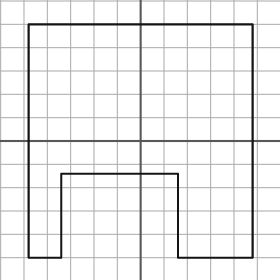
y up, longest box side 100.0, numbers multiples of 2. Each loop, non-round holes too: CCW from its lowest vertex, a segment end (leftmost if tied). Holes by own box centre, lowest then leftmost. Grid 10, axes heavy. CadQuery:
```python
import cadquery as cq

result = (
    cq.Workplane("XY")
    .moveTo(-48.0, -50.0)
    .lineTo(-34.0, -50.0)
    .lineTo(-34.0, -14.0)
    .lineTo(16.0, -14.0)
    .lineTo(16.0, -50.0)
    .lineTo(48.0, -50.0)
    .lineTo(48.0, 50.0)
    .lineTo(-48.0, 50.0)
    .close()
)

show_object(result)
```